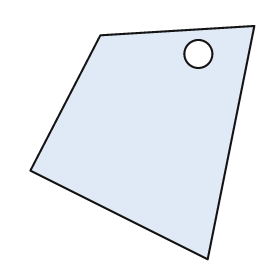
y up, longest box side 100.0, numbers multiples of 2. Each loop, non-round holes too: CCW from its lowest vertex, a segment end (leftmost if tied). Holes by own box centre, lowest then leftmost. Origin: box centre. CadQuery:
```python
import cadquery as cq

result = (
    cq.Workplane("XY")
    .moveTo(28.0, -50.0)
    .lineTo(48.0, 50.0)
    .lineTo(-18.0, 46.0)
    .lineTo(-48.0, -12.0)
    .close()
    .moveTo(24.0, 38.0)
    .circle(6.0)
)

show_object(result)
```